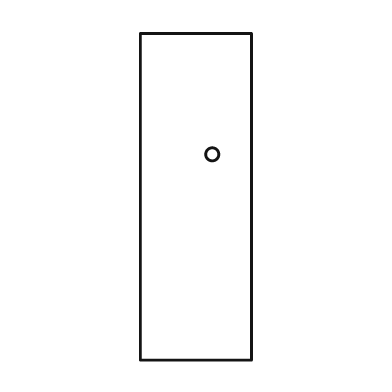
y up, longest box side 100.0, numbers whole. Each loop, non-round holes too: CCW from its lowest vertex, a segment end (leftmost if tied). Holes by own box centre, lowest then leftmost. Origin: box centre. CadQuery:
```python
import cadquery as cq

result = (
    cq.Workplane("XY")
    .moveTo(-17.0, -50.0)
    .lineTo(17.0, -50.0)
    .lineTo(17.0, 50.0)
    .lineTo(-17.0, 50.0)
    .close()
    .moveTo(5.0, 13.0)
    .circle(2.0)
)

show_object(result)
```